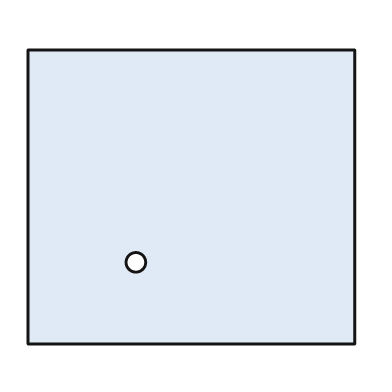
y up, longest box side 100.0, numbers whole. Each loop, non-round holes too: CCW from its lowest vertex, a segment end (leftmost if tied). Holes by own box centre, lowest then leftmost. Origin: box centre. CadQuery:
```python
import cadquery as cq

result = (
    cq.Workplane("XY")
    .moveTo(-50.0, -45.0)
    .lineTo(50.0, -45.0)
    .lineTo(50.0, 45.0)
    .lineTo(-50.0, 45.0)
    .close()
    .moveTo(-17.0, -20.0)
    .circle(3.0)
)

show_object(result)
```